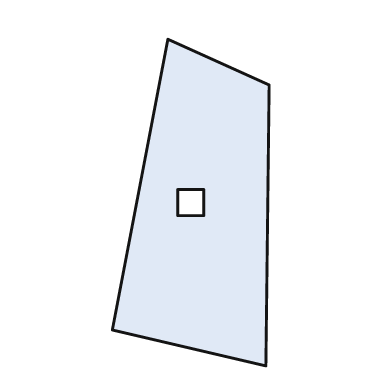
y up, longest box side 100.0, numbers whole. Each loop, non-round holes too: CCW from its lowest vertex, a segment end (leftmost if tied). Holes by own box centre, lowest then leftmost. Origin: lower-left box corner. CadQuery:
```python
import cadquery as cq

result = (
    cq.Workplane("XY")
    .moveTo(47.0, 0.0)
    .lineTo(48.0, 86.0)
    .lineTo(17.0, 100.0)
    .lineTo(0.0, 11.0)
    .close()
    .moveTo(20.0, 46.0)
    .lineTo(28.0, 46.0)
    .lineTo(28.0, 54.0)
    .lineTo(20.0, 54.0)
    .close()
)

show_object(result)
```